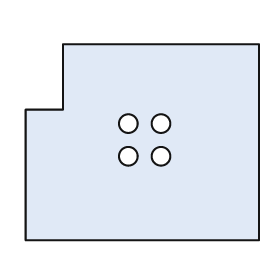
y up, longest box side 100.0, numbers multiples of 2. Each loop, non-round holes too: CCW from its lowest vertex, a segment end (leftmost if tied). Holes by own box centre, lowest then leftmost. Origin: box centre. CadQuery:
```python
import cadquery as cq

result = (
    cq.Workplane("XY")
    .moveTo(-50.0, -42.0)
    .lineTo(50.0, -42.0)
    .lineTo(50.0, 42.0)
    .lineTo(-34.0, 42.0)
    .lineTo(-34.0, 14.0)
    .lineTo(-50.0, 14.0)
    .close()
    .moveTo(-6.0, -6.0)
    .circle(4.0)
    .moveTo(8.0, -6.0)
    .circle(4.0)
    .moveTo(-6.0, 8.0)
    .circle(4.0)
    .moveTo(8.0, 8.0)
    .circle(4.0)
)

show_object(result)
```